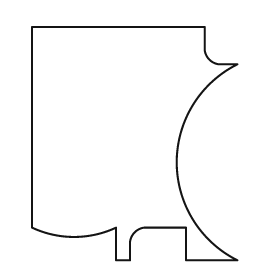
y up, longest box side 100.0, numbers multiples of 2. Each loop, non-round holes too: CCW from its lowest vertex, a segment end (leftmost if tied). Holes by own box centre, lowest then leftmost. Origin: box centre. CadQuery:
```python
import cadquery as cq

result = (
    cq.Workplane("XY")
    .moveTo(-8.0, -50.0)
    .lineTo(-2.0, -50.0)
    .lineTo(-2.0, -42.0)
    .threePointArc((0.0, -38.0), (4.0, -36.0))
    .lineTo(22.0, -36.0)
    .lineTo(22.0, -50.0)
    .lineTo(44.0, -50.0)
    .threePointArc((18.0, -8.0), (44.0, 34.0))
    .lineTo(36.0, 34.0)
    .threePointArc((32.0, 36.0), (30.0, 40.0))
    .lineTo(30.0, 50.0)
    .lineTo(-44.0, 50.0)
    .lineTo(-44.0, -36.0)
    .threePointArc((-26.0, -40.0), (-8.0, -36.0))
    .close()
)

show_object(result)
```